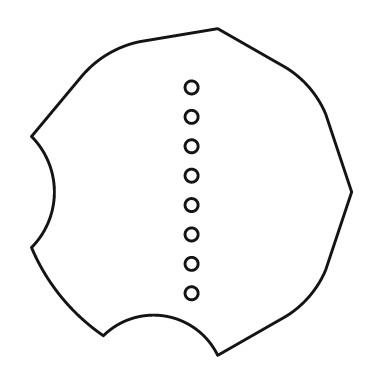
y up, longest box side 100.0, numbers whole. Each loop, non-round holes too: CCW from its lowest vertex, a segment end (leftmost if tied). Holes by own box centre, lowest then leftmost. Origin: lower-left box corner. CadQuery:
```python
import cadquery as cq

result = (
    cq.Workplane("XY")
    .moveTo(57.0, 0.0)
    .lineTo(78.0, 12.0)
    .threePointArc((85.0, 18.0), (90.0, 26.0))
    .lineTo(98.0, 50.0)
    .lineTo(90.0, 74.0)
    .threePointArc((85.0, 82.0), (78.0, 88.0))
    .lineTo(57.0, 100.0)
    .lineTo(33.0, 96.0)
    .threePointArc((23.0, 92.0), (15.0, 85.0))
    .lineTo(0.0, 67.0)
    .threePointArc((7.0, 50.0), (0.0, 33.0))
    .threePointArc((9.0, 18.0), (22.0, 6.0))
    .threePointArc((41.0, 12.0), (57.0, 0.0))
    .close()
    .moveTo(49.0, 19.0)
    .circle(2.0)
    .moveTo(49.0, 28.0)
    .circle(2.0)
    .moveTo(49.0, 37.0)
    .circle(2.0)
    .moveTo(49.0, 46.0)
    .circle(2.0)
    .moveTo(49.0, 55.0)
    .circle(2.0)
    .moveTo(49.0, 64.0)
    .circle(2.0)
    .moveTo(49.0, 73.0)
    .circle(2.0)
    .moveTo(49.0, 82.0)
    .circle(2.0)
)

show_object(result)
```